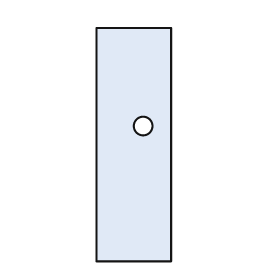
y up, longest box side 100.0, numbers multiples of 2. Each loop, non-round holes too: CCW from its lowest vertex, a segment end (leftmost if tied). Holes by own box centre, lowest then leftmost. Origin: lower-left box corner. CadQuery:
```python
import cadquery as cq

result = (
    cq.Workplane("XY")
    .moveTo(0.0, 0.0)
    .lineTo(32.0, 0.0)
    .lineTo(32.0, 100.0)
    .lineTo(0.0, 100.0)
    .close()
    .moveTo(20.0, 58.0)
    .circle(4.0)
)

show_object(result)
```